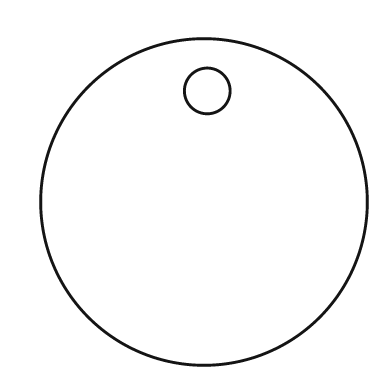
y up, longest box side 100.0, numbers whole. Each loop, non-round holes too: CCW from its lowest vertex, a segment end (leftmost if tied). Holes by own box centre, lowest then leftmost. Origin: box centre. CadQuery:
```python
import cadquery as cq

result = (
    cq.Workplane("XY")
    .moveTo(0.0, 0.0)
    .circle(50.0)
    .moveTo(1.0, 34.0)
    .circle(7.0)
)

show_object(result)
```